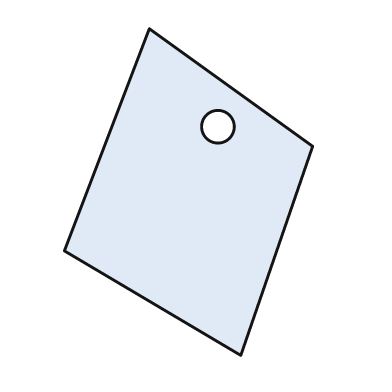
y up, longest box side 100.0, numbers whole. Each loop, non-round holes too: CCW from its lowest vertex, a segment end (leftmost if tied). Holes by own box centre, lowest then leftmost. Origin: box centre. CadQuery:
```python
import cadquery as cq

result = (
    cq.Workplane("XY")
    .moveTo(16.0, -50.0)
    .lineTo(38.0, 14.0)
    .lineTo(-12.0, 50.0)
    .lineTo(-38.0, -18.0)
    .close()
    .moveTo(9.0, 20.0)
    .circle(5.0)
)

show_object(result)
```